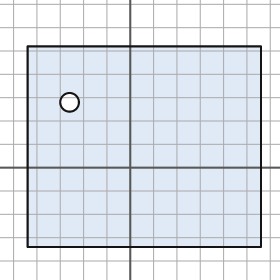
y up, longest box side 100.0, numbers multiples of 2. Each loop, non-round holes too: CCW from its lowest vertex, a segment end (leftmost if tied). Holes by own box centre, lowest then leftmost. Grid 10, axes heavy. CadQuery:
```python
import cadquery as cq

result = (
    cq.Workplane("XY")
    .moveTo(-44.0, -34.0)
    .lineTo(56.0, -34.0)
    .lineTo(56.0, 52.0)
    .lineTo(-44.0, 52.0)
    .close()
    .moveTo(-26.0, 28.0)
    .circle(4.0)
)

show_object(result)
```